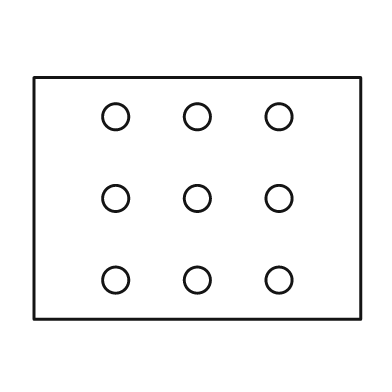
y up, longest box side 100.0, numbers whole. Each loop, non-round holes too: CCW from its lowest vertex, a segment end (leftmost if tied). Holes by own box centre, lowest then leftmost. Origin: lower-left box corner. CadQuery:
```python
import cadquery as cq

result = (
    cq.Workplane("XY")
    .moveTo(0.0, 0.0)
    .lineTo(100.0, 0.0)
    .lineTo(100.0, 74.0)
    .lineTo(0.0, 74.0)
    .close()
    .moveTo(25.0, 12.0)
    .circle(4.0)
    .moveTo(50.0, 12.0)
    .circle(4.0)
    .moveTo(75.0, 12.0)
    .circle(4.0)
    .moveTo(25.0, 37.0)
    .circle(4.0)
    .moveTo(50.0, 37.0)
    .circle(4.0)
    .moveTo(75.0, 37.0)
    .circle(4.0)
    .moveTo(25.0, 62.0)
    .circle(4.0)
    .moveTo(50.0, 62.0)
    .circle(4.0)
    .moveTo(75.0, 62.0)
    .circle(4.0)
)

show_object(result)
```